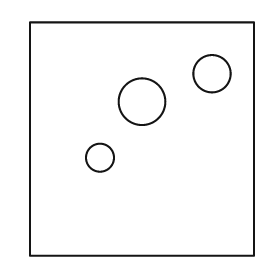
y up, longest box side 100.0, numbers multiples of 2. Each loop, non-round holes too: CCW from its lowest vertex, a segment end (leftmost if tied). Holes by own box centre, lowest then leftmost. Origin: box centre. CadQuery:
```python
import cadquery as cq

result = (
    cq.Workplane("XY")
    .moveTo(-48.0, -50.0)
    .lineTo(48.0, -50.0)
    .lineTo(48.0, 50.0)
    .lineTo(-48.0, 50.0)
    .close()
    .moveTo(-18.0, -8.0)
    .circle(6.0)
    .moveTo(0.0, 16.0)
    .circle(10.0)
    .moveTo(30.0, 28.0)
    .circle(8.0)
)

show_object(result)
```